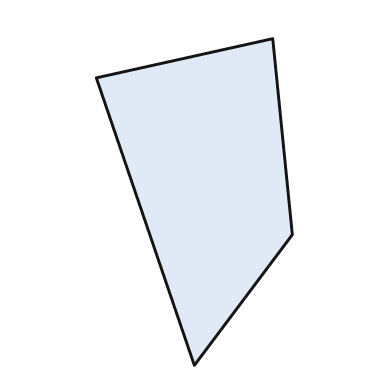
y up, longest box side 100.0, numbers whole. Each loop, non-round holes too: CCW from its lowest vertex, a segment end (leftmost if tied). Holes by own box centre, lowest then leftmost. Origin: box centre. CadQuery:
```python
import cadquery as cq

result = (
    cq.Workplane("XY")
    .moveTo(0.0, -50.0)
    .lineTo(30.0, -10.0)
    .lineTo(24.0, 50.0)
    .lineTo(-30.0, 38.0)
    .close()
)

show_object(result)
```